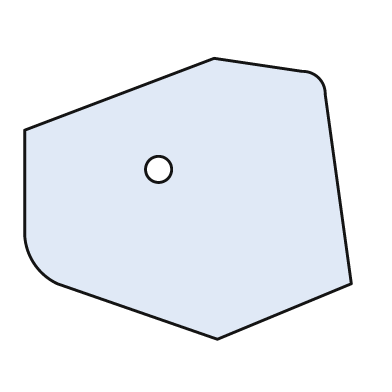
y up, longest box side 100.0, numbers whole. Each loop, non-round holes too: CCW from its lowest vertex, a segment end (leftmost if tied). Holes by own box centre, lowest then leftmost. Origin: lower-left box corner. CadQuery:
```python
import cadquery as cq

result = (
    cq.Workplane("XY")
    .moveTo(59.0, 0.0)
    .lineTo(100.0, 17.0)
    .lineTo(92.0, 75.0)
    .threePointArc((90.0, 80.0), (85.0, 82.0))
    .lineTo(58.0, 86.0)
    .lineTo(0.0, 64.0)
    .lineTo(0.0, 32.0)
    .threePointArc((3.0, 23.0), (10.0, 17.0))
    .close()
    .moveTo(41.0, 52.0)
    .circle(4.0)
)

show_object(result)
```